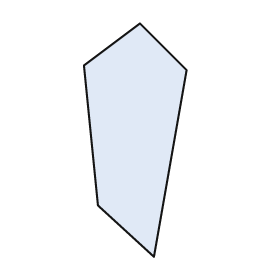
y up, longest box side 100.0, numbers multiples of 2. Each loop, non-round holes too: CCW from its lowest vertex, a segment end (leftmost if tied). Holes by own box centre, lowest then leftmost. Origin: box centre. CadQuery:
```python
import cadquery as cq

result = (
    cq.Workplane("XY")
    .moveTo(8.0, -50.0)
    .lineTo(22.0, 30.0)
    .lineTo(2.0, 50.0)
    .lineTo(-22.0, 32.0)
    .lineTo(-16.0, -28.0)
    .close()
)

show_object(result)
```